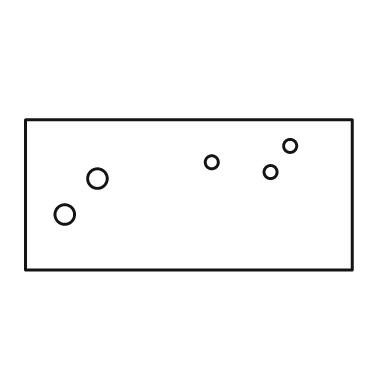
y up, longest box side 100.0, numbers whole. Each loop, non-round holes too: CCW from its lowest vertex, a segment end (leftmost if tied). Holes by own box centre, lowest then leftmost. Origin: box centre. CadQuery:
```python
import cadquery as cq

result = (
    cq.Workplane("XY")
    .moveTo(-50.0, -23.0)
    .lineTo(50.0, -23.0)
    .lineTo(50.0, 23.0)
    .lineTo(-50.0, 23.0)
    .close()
    .moveTo(-38.0, -6.0)
    .circle(3.0)
    .moveTo(-28.0, 5.0)
    .circle(3.0)
    .moveTo(25.0, 7.0)
    .circle(2.0)
    .moveTo(7.0, 10.0)
    .circle(2.0)
    .moveTo(31.0, 15.0)
    .circle(2.0)
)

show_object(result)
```